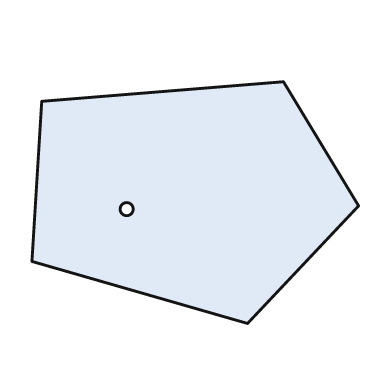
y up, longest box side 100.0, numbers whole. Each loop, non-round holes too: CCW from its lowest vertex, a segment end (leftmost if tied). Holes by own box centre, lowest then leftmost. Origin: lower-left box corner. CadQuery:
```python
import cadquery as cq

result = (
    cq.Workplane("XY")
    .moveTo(66.0, 0.0)
    .lineTo(100.0, 36.0)
    .lineTo(77.0, 74.0)
    .lineTo(3.0, 68.0)
    .lineTo(0.0, 19.0)
    .close()
    .moveTo(29.0, 35.0)
    .circle(2.0)
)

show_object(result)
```